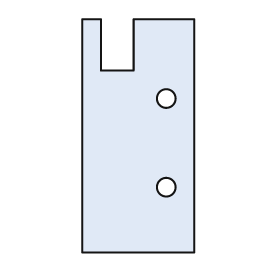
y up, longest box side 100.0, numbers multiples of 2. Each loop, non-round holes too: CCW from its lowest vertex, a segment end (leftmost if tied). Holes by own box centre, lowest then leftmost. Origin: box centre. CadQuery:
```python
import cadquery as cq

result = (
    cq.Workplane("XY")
    .moveTo(-24.0, -50.0)
    .lineTo(24.0, -50.0)
    .lineTo(24.0, 50.0)
    .lineTo(-2.0, 50.0)
    .lineTo(-2.0, 28.0)
    .lineTo(-16.0, 28.0)
    .lineTo(-16.0, 50.0)
    .lineTo(-24.0, 50.0)
    .close()
    .moveTo(12.0, -22.0)
    .circle(4.0)
    .moveTo(12.0, 16.0)
    .circle(4.0)
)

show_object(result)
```